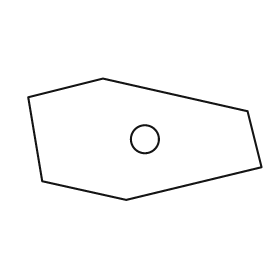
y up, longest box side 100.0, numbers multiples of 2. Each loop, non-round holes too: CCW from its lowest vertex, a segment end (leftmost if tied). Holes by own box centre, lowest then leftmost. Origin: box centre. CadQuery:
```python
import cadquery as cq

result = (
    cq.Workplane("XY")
    .moveTo(-8.0, -26.0)
    .lineTo(50.0, -12.0)
    .lineTo(44.0, 12.0)
    .lineTo(-18.0, 26.0)
    .lineTo(-50.0, 18.0)
    .lineTo(-44.0, -18.0)
    .close()
    .moveTo(0.0, 0.0)
    .circle(6.0)
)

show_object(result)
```